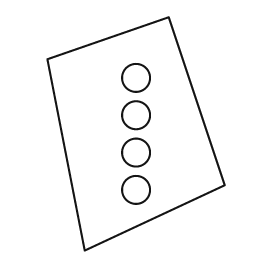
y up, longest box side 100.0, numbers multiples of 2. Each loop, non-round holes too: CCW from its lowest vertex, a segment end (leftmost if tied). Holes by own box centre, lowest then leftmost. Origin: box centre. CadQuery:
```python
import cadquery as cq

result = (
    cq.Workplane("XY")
    .moveTo(-22.0, -50.0)
    .lineTo(38.0, -22.0)
    .lineTo(14.0, 50.0)
    .lineTo(-38.0, 32.0)
    .close()
    .moveTo(0.0, -24.0)
    .circle(6.0)
    .moveTo(0.0, -8.0)
    .circle(6.0)
    .moveTo(0.0, 8.0)
    .circle(6.0)
    .moveTo(0.0, 24.0)
    .circle(6.0)
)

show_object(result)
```